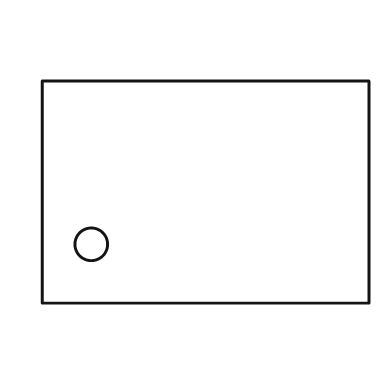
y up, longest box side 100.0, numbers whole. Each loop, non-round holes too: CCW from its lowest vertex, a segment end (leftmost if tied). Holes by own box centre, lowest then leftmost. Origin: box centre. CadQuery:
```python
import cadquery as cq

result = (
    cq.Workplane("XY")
    .moveTo(-50.0, -34.0)
    .lineTo(50.0, -34.0)
    .lineTo(50.0, 34.0)
    .lineTo(-50.0, 34.0)
    .close()
    .moveTo(-35.0, -16.0)
    .circle(5.0)
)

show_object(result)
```